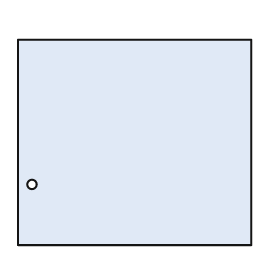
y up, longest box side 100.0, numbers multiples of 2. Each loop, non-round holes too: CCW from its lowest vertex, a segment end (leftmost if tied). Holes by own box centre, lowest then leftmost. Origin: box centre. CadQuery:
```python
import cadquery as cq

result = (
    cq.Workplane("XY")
    .moveTo(-50.0, -44.0)
    .lineTo(50.0, -44.0)
    .lineTo(50.0, 44.0)
    .lineTo(-50.0, 44.0)
    .close()
    .moveTo(-44.0, -18.0)
    .circle(2.0)
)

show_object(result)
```